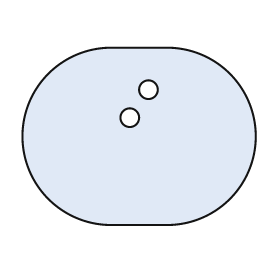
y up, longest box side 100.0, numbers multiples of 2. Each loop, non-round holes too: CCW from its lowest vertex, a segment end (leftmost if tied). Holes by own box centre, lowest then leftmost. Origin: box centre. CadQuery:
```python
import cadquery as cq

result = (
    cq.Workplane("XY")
    .moveTo(-12.0, -38.0)
    .lineTo(12.0, -38.0)
    .threePointArc((50.0, 0.0), (12.0, 38.0))
    .lineTo(-12.0, 38.0)
    .threePointArc((-50.0, 0.0), (-12.0, -38.0))
    .close()
    .moveTo(-4.0, 8.0)
    .circle(4.0)
    .moveTo(4.0, 20.0)
    .circle(4.0)
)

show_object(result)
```